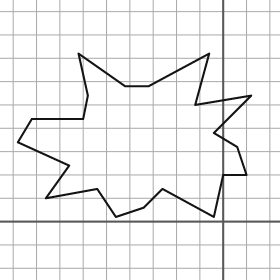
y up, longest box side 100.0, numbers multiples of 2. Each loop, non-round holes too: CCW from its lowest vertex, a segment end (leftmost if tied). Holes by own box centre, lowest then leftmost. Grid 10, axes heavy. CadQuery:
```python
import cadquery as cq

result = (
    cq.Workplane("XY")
    .moveTo(-46.0, 2.0)
    .lineTo(-34.0, 6.0)
    .lineTo(-26.0, 14.0)
    .lineTo(-4.0, 2.0)
    .lineTo(0.0, 20.0)
    .lineTo(10.0, 20.0)
    .lineTo(6.0, 32.0)
    .lineTo(-4.0, 38.0)
    .lineTo(12.0, 54.0)
    .lineTo(-12.0, 50.0)
    .lineTo(-6.0, 72.0)
    .lineTo(-32.0, 58.0)
    .lineTo(-42.0, 58.0)
    .lineTo(-62.0, 72.0)
    .lineTo(-58.0, 54.0)
    .lineTo(-60.0, 44.0)
    .lineTo(-82.0, 44.0)
    .lineTo(-88.0, 34.0)
    .lineTo(-66.0, 24.0)
    .lineTo(-76.0, 10.0)
    .lineTo(-54.0, 14.0)
    .close()
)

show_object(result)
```